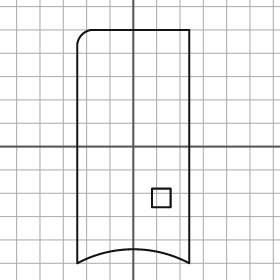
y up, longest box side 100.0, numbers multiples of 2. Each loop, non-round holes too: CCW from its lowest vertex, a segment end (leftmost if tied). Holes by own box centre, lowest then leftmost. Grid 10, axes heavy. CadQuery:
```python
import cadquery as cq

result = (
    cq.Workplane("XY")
    .moveTo(-24.0, -50.0)
    .threePointArc((0.0, -44.0), (24.0, -50.0))
    .lineTo(24.0, 50.0)
    .lineTo(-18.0, 50.0)
    .threePointArc((-22.0, 48.0), (-24.0, 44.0))
    .close()
    .moveTo(8.0, -26.0)
    .lineTo(16.0, -26.0)
    .lineTo(16.0, -18.0)
    .lineTo(8.0, -18.0)
    .close()
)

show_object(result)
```